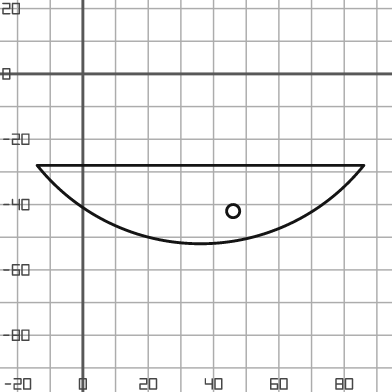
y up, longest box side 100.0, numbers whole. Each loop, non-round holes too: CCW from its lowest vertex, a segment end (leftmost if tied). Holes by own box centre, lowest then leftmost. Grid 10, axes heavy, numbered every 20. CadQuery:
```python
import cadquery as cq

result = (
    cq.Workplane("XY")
    .moveTo(-14.0, -28.0)
    .threePointArc((36.0, -52.0), (86.0, -28.0))
    .close()
    .moveTo(46.0, -42.0)
    .circle(2.0)
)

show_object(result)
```